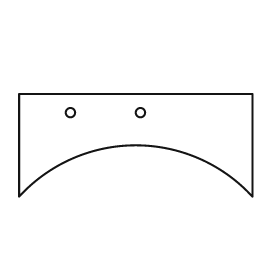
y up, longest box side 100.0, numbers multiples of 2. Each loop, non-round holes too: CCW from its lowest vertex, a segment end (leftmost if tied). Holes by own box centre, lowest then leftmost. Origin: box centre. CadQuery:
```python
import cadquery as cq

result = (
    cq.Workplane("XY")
    .moveTo(-50.0, -22.0)
    .threePointArc((0.0, 0.0), (50.0, -22.0))
    .lineTo(50.0, 22.0)
    .lineTo(-50.0, 22.0)
    .close()
    .moveTo(-28.0, 14.0)
    .circle(2.0)
    .moveTo(2.0, 14.0)
    .circle(2.0)
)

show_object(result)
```